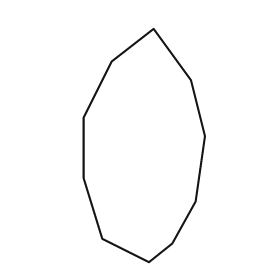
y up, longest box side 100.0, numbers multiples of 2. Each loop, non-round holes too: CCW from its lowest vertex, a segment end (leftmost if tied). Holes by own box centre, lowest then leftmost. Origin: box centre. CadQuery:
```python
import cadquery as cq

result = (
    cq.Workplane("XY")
    .moveTo(2.0, -50.0)
    .lineTo(12.0, -42.0)
    .lineTo(22.0, -24.0)
    .lineTo(26.0, 4.0)
    .lineTo(20.0, 28.0)
    .lineTo(4.0, 50.0)
    .lineTo(-14.0, 36.0)
    .lineTo(-26.0, 12.0)
    .lineTo(-26.0, -14.0)
    .lineTo(-18.0, -40.0)
    .close()
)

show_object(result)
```